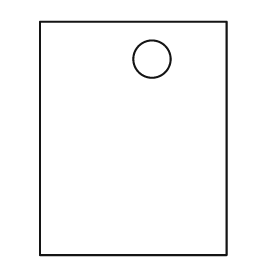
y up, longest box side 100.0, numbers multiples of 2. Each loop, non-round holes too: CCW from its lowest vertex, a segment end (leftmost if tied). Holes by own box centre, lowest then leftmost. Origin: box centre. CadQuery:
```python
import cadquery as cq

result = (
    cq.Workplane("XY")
    .moveTo(-40.0, -50.0)
    .lineTo(40.0, -50.0)
    .lineTo(40.0, 50.0)
    .lineTo(-40.0, 50.0)
    .close()
    .moveTo(8.0, 34.0)
    .circle(8.0)
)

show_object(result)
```